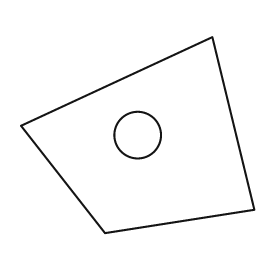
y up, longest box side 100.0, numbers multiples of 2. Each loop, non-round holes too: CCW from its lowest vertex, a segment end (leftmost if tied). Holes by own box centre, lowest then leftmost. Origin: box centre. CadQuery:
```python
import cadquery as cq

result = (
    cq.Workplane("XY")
    .moveTo(-14.0, -42.0)
    .lineTo(50.0, -32.0)
    .lineTo(32.0, 42.0)
    .lineTo(-50.0, 4.0)
    .close()
    .moveTo(0.0, 0.0)
    .circle(10.0)
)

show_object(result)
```